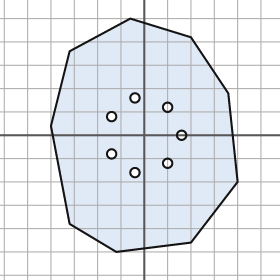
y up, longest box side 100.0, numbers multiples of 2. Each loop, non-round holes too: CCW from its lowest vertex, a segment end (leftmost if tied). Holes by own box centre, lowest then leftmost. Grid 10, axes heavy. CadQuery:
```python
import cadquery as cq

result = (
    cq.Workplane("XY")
    .moveTo(-12.0, -50.0)
    .lineTo(20.0, -46.0)
    .lineTo(40.0, -20.0)
    .lineTo(36.0, 18.0)
    .lineTo(20.0, 42.0)
    .lineTo(-6.0, 50.0)
    .lineTo(-32.0, 36.0)
    .lineTo(-40.0, 4.0)
    .lineTo(-32.0, -38.0)
    .close()
    .moveTo(-4.0, -16.0)
    .circle(2.0)
    .moveTo(10.0, -12.0)
    .circle(2.0)
    .moveTo(-14.0, -8.0)
    .circle(2.0)
    .moveTo(16.0, 0.0)
    .circle(2.0)
    .moveTo(-14.0, 8.0)
    .circle(2.0)
    .moveTo(10.0, 12.0)
    .circle(2.0)
    .moveTo(-4.0, 16.0)
    .circle(2.0)
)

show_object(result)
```